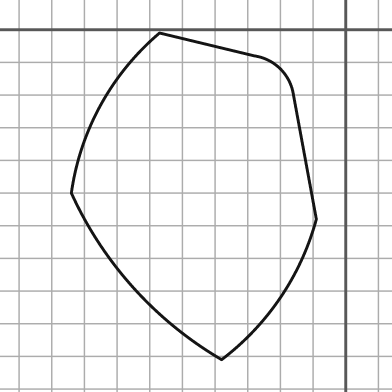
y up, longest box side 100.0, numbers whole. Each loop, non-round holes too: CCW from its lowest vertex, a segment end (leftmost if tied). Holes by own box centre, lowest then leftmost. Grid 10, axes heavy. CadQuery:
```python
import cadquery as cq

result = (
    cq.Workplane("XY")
    .moveTo(-38.0, -101.0)
    .threePointArc((-20.0, -82.0), (-9.0, -58.0))
    .lineTo(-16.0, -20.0)
    .threePointArc((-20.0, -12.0), (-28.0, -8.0))
    .lineTo(-57.0, -1.0)
    .threePointArc((-75.0, -23.0), (-84.0, -50.0))
    .threePointArc((-65.0, -79.0), (-38.0, -101.0))
    .close()
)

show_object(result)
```